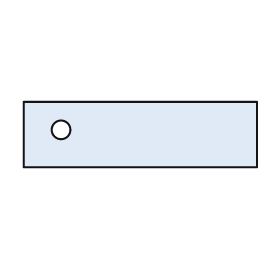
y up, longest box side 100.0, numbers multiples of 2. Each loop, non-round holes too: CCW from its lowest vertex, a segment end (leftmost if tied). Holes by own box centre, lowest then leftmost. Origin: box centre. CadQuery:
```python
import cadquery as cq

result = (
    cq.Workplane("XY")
    .moveTo(-50.0, -14.0)
    .lineTo(50.0, -14.0)
    .lineTo(50.0, 14.0)
    .lineTo(-50.0, 14.0)
    .close()
    .moveTo(-34.0, 2.0)
    .circle(4.0)
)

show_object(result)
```